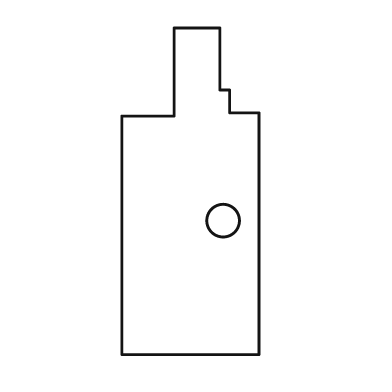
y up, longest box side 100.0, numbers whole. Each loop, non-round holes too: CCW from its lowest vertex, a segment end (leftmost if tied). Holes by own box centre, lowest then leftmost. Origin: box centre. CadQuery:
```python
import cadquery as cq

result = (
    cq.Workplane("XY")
    .moveTo(-21.0, -50.0)
    .lineTo(21.0, -50.0)
    .lineTo(21.0, 24.0)
    .lineTo(12.0, 24.0)
    .lineTo(12.0, 31.0)
    .lineTo(9.0, 31.0)
    .lineTo(9.0, 50.0)
    .lineTo(-5.0, 50.0)
    .lineTo(-5.0, 23.0)
    .lineTo(-21.0, 23.0)
    .close()
    .moveTo(10.0, -9.0)
    .circle(5.0)
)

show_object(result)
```